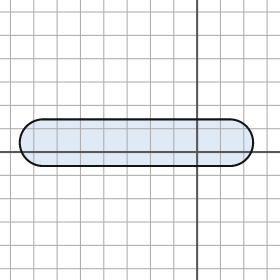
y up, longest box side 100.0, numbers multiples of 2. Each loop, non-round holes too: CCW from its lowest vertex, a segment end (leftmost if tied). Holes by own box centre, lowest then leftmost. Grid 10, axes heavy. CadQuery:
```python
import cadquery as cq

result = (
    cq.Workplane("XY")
    .moveTo(-66.0, -6.0)
    .lineTo(14.0, -6.0)
    .threePointArc((24.0, 4.0), (14.0, 14.0))
    .lineTo(-66.0, 14.0)
    .threePointArc((-76.0, 4.0), (-66.0, -6.0))
    .close()
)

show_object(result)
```